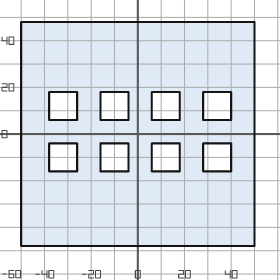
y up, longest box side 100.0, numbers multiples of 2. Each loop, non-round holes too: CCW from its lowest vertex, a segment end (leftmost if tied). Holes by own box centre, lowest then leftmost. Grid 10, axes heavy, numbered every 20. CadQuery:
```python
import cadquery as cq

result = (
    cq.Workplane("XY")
    .moveTo(-50.0, -48.0)
    .lineTo(50.0, -48.0)
    .lineTo(50.0, 48.0)
    .lineTo(-50.0, 48.0)
    .close()
    .moveTo(-38.0, -16.0)
    .lineTo(-26.0, -16.0)
    .lineTo(-26.0, -4.0)
    .lineTo(-38.0, -4.0)
    .close()
    .moveTo(-16.0, -16.0)
    .lineTo(-4.0, -16.0)
    .lineTo(-4.0, -4.0)
    .lineTo(-16.0, -4.0)
    .close()
    .moveTo(6.0, -16.0)
    .lineTo(18.0, -16.0)
    .lineTo(18.0, -4.0)
    .lineTo(6.0, -4.0)
    .close()
    .moveTo(28.0, -16.0)
    .lineTo(40.0, -16.0)
    .lineTo(40.0, -4.0)
    .lineTo(28.0, -4.0)
    .close()
    .moveTo(-38.0, 6.0)
    .lineTo(-26.0, 6.0)
    .lineTo(-26.0, 18.0)
    .lineTo(-38.0, 18.0)
    .close()
    .moveTo(-16.0, 6.0)
    .lineTo(-4.0, 6.0)
    .lineTo(-4.0, 18.0)
    .lineTo(-16.0, 18.0)
    .close()
    .moveTo(6.0, 6.0)
    .lineTo(18.0, 6.0)
    .lineTo(18.0, 18.0)
    .lineTo(6.0, 18.0)
    .close()
    .moveTo(28.0, 6.0)
    .lineTo(40.0, 6.0)
    .lineTo(40.0, 18.0)
    .lineTo(28.0, 18.0)
    .close()
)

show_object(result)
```